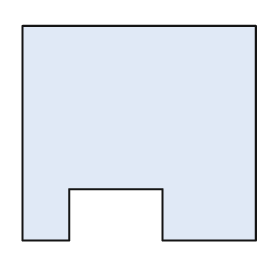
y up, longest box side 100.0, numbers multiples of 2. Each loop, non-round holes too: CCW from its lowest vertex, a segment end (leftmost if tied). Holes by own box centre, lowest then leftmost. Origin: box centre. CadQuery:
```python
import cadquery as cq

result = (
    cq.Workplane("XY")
    .moveTo(-50.0, -46.0)
    .lineTo(-30.0, -46.0)
    .lineTo(-30.0, -24.0)
    .lineTo(10.0, -24.0)
    .lineTo(10.0, -46.0)
    .lineTo(50.0, -46.0)
    .lineTo(50.0, 46.0)
    .lineTo(-50.0, 46.0)
    .close()
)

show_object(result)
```